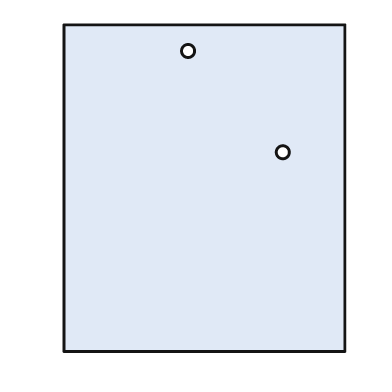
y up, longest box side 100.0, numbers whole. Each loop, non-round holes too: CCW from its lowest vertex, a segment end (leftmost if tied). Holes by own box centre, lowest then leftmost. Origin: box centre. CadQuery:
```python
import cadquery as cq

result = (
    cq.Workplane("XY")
    .moveTo(-43.0, -50.0)
    .lineTo(43.0, -50.0)
    .lineTo(43.0, 50.0)
    .lineTo(-43.0, 50.0)
    .close()
    .moveTo(24.0, 11.0)
    .circle(2.0)
    .moveTo(-5.0, 42.0)
    .circle(2.0)
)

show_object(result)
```